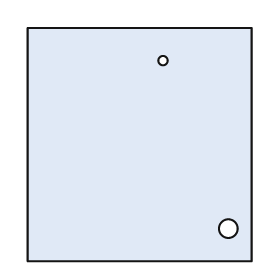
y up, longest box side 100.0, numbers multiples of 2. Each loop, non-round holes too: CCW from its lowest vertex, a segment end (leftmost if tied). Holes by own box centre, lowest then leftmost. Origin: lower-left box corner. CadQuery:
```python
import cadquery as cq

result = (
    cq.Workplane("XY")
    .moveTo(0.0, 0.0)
    .lineTo(96.0, 0.0)
    .lineTo(96.0, 100.0)
    .lineTo(0.0, 100.0)
    .close()
    .moveTo(86.0, 14.0)
    .circle(4.0)
    .moveTo(58.0, 86.0)
    .circle(2.0)
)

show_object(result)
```